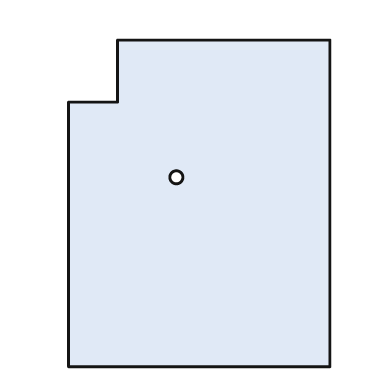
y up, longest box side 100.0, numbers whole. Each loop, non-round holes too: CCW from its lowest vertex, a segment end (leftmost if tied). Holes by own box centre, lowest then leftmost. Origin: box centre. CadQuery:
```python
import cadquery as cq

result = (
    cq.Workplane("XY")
    .moveTo(-40.0, -50.0)
    .lineTo(40.0, -50.0)
    .lineTo(40.0, 50.0)
    .lineTo(-25.0, 50.0)
    .lineTo(-25.0, 31.0)
    .lineTo(-40.0, 31.0)
    .close()
    .moveTo(-7.0, 8.0)
    .circle(2.0)
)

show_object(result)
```